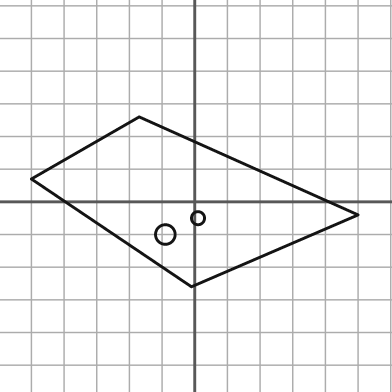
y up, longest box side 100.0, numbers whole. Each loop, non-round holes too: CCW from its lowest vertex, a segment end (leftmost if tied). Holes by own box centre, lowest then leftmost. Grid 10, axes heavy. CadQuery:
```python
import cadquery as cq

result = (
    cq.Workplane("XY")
    .moveTo(-1.0, -26.0)
    .lineTo(50.0, -4.0)
    .lineTo(-17.0, 26.0)
    .lineTo(-50.0, 7.0)
    .close()
    .moveTo(-9.0, -10.0)
    .circle(3.0)
    .moveTo(1.0, -5.0)
    .circle(2.0)
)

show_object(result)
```